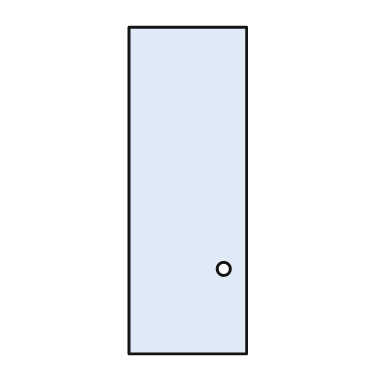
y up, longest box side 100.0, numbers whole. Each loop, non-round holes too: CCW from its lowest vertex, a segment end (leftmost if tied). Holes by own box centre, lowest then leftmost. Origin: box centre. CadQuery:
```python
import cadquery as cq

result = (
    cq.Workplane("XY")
    .moveTo(-18.0, -50.0)
    .lineTo(18.0, -50.0)
    .lineTo(18.0, 50.0)
    .lineTo(-18.0, 50.0)
    .close()
    .moveTo(11.0, -24.0)
    .circle(2.0)
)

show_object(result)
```